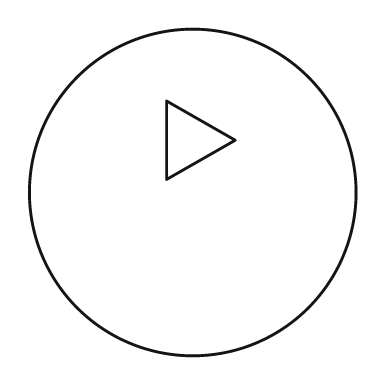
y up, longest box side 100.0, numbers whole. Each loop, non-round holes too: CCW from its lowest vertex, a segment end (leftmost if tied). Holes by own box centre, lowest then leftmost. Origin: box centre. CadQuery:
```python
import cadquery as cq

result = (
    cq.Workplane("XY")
    .moveTo(0.0, 0.0)
    .circle(50.0)
    .moveTo(-8.0, 4.0)
    .lineTo(13.0, 16.0)
    .lineTo(-8.0, 28.0)
    .close()
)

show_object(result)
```